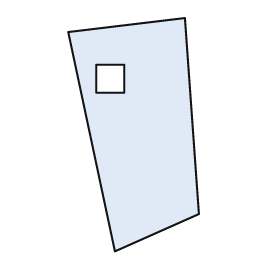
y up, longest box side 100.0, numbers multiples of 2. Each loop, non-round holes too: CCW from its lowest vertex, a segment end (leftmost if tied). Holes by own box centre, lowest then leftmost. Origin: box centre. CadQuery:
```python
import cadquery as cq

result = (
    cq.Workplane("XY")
    .moveTo(-8.0, -50.0)
    .lineTo(28.0, -34.0)
    .lineTo(22.0, 50.0)
    .lineTo(-28.0, 44.0)
    .close()
    .moveTo(-16.0, 18.0)
    .lineTo(-4.0, 18.0)
    .lineTo(-4.0, 30.0)
    .lineTo(-16.0, 30.0)
    .close()
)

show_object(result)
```